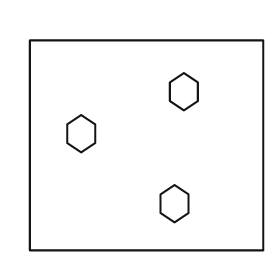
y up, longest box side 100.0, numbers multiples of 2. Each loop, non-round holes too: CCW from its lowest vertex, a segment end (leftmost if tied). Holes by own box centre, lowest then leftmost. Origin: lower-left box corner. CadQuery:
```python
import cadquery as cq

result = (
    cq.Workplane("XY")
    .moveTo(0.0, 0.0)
    .lineTo(100.0, 0.0)
    .lineTo(100.0, 90.0)
    .lineTo(0.0, 90.0)
    .close()
    .moveTo(62.0, 12.0)
    .lineTo(68.0, 16.0)
    .lineTo(68.0, 24.0)
    .lineTo(62.0, 28.0)
    .lineTo(56.0, 24.0)
    .lineTo(56.0, 16.0)
    .close()
    .moveTo(22.0, 42.0)
    .lineTo(28.0, 46.0)
    .lineTo(28.0, 54.0)
    .lineTo(22.0, 58.0)
    .lineTo(16.0, 54.0)
    .lineTo(16.0, 46.0)
    .close()
    .moveTo(66.0, 60.0)
    .lineTo(72.0, 64.0)
    .lineTo(72.0, 72.0)
    .lineTo(66.0, 76.0)
    .lineTo(60.0, 72.0)
    .lineTo(60.0, 64.0)
    .close()
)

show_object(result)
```